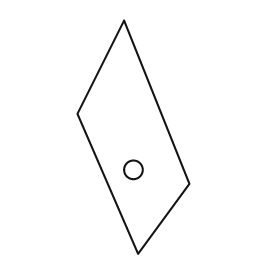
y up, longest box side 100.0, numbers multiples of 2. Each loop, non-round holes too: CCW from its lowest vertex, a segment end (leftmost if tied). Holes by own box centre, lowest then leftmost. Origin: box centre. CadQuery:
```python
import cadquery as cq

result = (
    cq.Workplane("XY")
    .moveTo(2.0, -50.0)
    .lineTo(24.0, -20.0)
    .lineTo(-4.0, 50.0)
    .lineTo(-24.0, 10.0)
    .close()
    .moveTo(0.0, -14.0)
    .circle(4.0)
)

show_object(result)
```